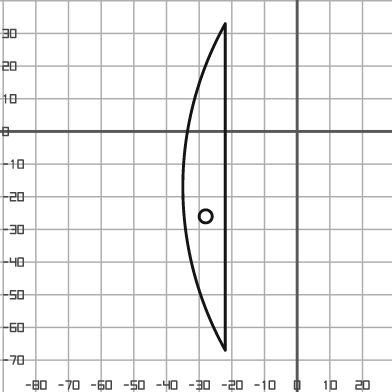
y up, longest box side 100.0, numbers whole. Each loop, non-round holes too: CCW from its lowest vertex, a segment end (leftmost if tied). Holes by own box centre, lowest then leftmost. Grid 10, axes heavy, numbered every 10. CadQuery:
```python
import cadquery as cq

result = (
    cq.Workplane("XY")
    .moveTo(-22.0, -67.0)
    .lineTo(-22.0, 33.0)
    .threePointArc((-35.0, -17.0), (-22.0, -67.0))
    .close()
    .moveTo(-28.0, -26.0)
    .circle(2.0)
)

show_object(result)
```